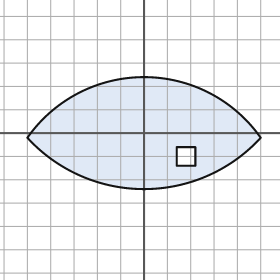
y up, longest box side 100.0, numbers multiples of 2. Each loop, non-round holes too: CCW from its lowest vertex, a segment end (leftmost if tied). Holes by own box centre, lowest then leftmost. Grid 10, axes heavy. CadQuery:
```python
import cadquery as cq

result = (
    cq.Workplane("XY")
    .moveTo(-50.0, -2.0)
    .threePointArc((0.0, -24.0), (50.0, -2.0))
    .threePointArc((0.0, 24.0), (-50.0, -2.0))
    .close()
    .moveTo(14.0, -14.0)
    .lineTo(22.0, -14.0)
    .lineTo(22.0, -6.0)
    .lineTo(14.0, -6.0)
    .close()
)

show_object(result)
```